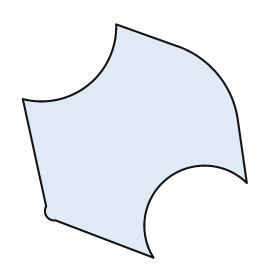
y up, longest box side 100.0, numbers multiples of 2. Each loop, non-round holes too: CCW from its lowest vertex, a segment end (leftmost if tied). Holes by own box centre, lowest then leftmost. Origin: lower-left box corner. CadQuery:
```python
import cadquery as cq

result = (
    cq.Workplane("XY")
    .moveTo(56.0, 0.0)
    .threePointArc((62.0, 34.0), (96.0, 32.0))
    .lineTo(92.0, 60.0)
    .threePointArc((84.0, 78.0), (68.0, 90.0))
    .lineTo(40.0, 100.0)
    .threePointArc((28.0, 74.0), (0.0, 68.0))
    .lineTo(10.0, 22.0)
    .threePointArc((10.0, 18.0), (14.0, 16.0))
    .close()
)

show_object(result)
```